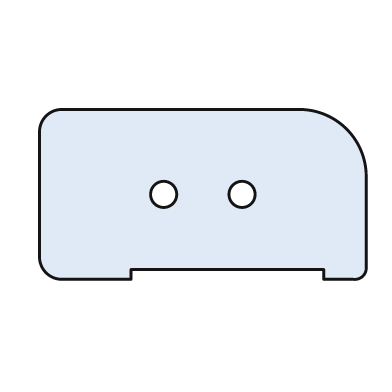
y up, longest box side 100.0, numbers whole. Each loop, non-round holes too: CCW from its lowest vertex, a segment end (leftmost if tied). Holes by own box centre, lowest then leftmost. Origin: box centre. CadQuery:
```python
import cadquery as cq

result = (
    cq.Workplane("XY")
    .moveTo(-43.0, -26.0)
    .lineTo(-22.0, -26.0)
    .lineTo(-22.0, -23.0)
    .lineTo(37.0, -23.0)
    .lineTo(37.0, -26.0)
    .lineTo(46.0, -26.0)
    .threePointArc((49.0, -25.0), (50.0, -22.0))
    .lineTo(50.0, 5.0)
    .threePointArc((44.0, 20.0), (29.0, 26.0))
    .lineTo(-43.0, 26.0)
    .threePointArc((-48.0, 24.0), (-50.0, 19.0))
    .lineTo(-50.0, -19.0)
    .threePointArc((-48.0, -24.0), (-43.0, -26.0))
    .close()
    .moveTo(-12.0, 0.0)
    .circle(4.0)
    .moveTo(12.0, 0.0)
    .circle(4.0)
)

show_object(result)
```